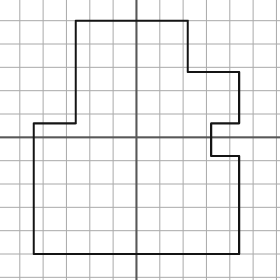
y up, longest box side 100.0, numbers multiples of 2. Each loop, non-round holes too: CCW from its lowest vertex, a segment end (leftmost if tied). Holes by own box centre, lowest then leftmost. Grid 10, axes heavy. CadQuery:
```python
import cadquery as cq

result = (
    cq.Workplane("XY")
    .moveTo(-44.0, -50.0)
    .lineTo(44.0, -50.0)
    .lineTo(44.0, -8.0)
    .lineTo(32.0, -8.0)
    .lineTo(32.0, 6.0)
    .lineTo(44.0, 6.0)
    .lineTo(44.0, 28.0)
    .lineTo(22.0, 28.0)
    .lineTo(22.0, 50.0)
    .lineTo(-26.0, 50.0)
    .lineTo(-26.0, 6.0)
    .lineTo(-44.0, 6.0)
    .close()
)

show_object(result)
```